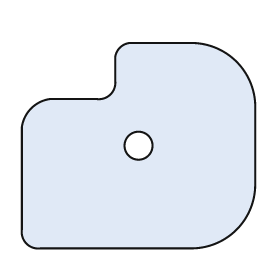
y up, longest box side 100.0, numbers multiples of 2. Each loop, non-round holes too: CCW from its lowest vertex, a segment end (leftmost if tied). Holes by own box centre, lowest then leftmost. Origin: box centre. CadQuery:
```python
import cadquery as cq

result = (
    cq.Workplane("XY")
    .moveTo(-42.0, -44.0)
    .lineTo(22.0, -44.0)
    .threePointArc((42.0, -36.0), (50.0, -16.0))
    .lineTo(50.0, 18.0)
    .threePointArc((42.0, 36.0), (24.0, 44.0))
    .lineTo(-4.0, 44.0)
    .threePointArc((-8.0, 42.0), (-10.0, 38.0))
    .lineTo(-10.0, 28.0)
    .threePointArc((-12.0, 22.0), (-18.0, 20.0))
    .lineTo(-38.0, 20.0)
    .threePointArc((-46.0, 16.0), (-50.0, 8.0))
    .lineTo(-50.0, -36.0)
    .threePointArc((-48.0, -42.0), (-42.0, -44.0))
    .close()
    .moveTo(0.0, 0.0)
    .circle(6.0)
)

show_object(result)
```